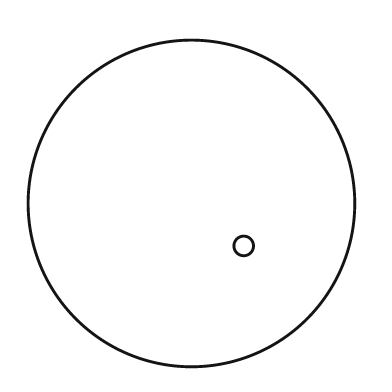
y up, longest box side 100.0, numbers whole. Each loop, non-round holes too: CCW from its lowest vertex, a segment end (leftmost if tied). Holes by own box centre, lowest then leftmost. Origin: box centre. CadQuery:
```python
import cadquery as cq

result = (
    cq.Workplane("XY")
    .moveTo(0.0, 0.0)
    .circle(50.0)
    .moveTo(16.0, -13.0)
    .circle(3.0)
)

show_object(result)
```